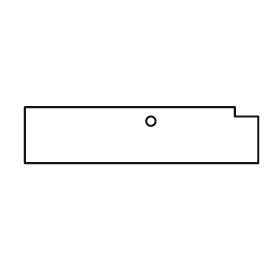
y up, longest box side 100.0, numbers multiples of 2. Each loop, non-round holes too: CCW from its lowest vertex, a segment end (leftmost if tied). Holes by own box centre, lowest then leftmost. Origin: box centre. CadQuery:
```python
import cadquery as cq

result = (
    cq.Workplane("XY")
    .moveTo(-50.0, -12.0)
    .lineTo(50.0, -12.0)
    .lineTo(50.0, 8.0)
    .lineTo(40.0, 8.0)
    .lineTo(40.0, 12.0)
    .lineTo(-50.0, 12.0)
    .close()
    .moveTo(4.0, 6.0)
    .circle(2.0)
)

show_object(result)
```